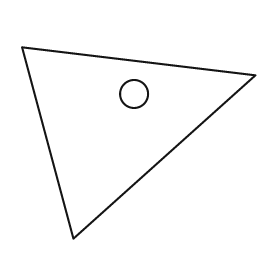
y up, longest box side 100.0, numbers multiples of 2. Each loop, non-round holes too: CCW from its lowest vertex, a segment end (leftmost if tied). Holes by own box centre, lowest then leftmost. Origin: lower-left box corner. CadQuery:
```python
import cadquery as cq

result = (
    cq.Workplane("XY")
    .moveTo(22.0, 0.0)
    .lineTo(100.0, 70.0)
    .lineTo(0.0, 82.0)
    .close()
    .moveTo(48.0, 62.0)
    .circle(6.0)
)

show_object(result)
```